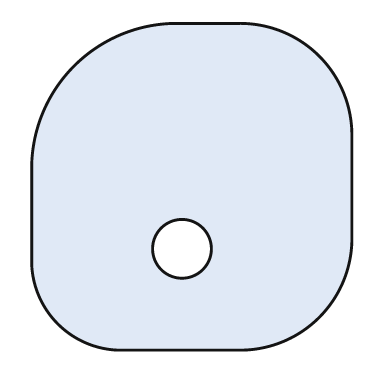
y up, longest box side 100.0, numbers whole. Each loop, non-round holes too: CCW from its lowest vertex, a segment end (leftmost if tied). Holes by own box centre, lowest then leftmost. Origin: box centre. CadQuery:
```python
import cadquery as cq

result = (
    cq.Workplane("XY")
    .moveTo(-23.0, -50.0)
    .lineTo(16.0, -50.0)
    .threePointArc((39.0, -40.0), (49.0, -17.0))
    .lineTo(49.0, 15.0)
    .threePointArc((39.0, 40.0), (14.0, 50.0))
    .lineTo(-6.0, 50.0)
    .threePointArc((-36.0, 37.0), (-49.0, 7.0))
    .lineTo(-49.0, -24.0)
    .threePointArc((-41.0, -42.0), (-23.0, -50.0))
    .close()
    .moveTo(-3.0, -19.0)
    .circle(9.0)
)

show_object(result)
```